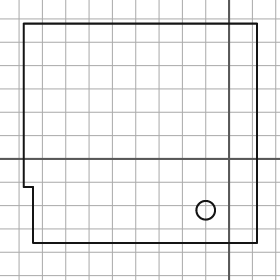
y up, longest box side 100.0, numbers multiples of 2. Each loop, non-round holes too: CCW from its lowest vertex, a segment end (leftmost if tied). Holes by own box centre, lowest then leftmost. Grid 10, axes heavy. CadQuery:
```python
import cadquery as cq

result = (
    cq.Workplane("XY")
    .moveTo(-84.0, -36.0)
    .lineTo(12.0, -36.0)
    .lineTo(12.0, 58.0)
    .lineTo(-88.0, 58.0)
    .lineTo(-88.0, -12.0)
    .lineTo(-84.0, -12.0)
    .close()
    .moveTo(-10.0, -22.0)
    .circle(4.0)
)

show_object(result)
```